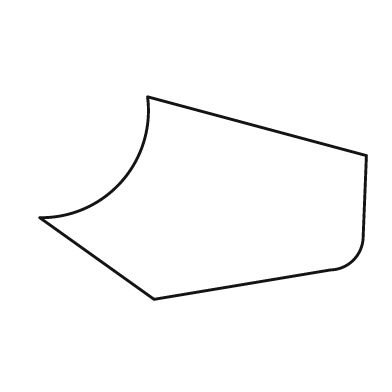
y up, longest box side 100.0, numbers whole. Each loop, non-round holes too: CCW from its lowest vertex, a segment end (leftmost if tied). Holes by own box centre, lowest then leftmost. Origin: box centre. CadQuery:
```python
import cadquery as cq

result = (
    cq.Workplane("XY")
    .moveTo(-15.0, -31.0)
    .lineTo(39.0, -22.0)
    .threePointArc((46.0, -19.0), (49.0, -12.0))
    .lineTo(50.0, 13.0)
    .lineTo(-17.0, 31.0)
    .threePointArc((-25.0, 5.0), (-50.0, -6.0))
    .close()
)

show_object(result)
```